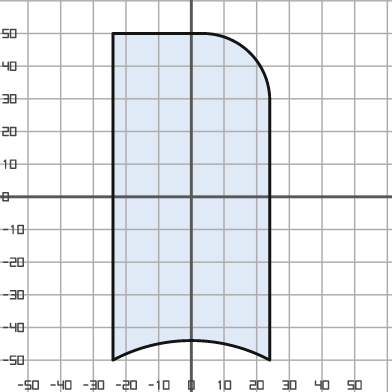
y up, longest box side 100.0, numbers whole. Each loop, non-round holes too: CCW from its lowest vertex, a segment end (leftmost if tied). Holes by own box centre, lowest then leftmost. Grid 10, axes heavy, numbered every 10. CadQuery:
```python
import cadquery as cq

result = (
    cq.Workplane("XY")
    .moveTo(-24.0, -50.0)
    .threePointArc((0.0, -44.0), (24.0, -50.0))
    .lineTo(24.0, 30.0)
    .threePointArc((18.0, 44.0), (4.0, 50.0))
    .lineTo(-24.0, 50.0)
    .close()
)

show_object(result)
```